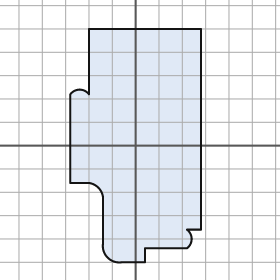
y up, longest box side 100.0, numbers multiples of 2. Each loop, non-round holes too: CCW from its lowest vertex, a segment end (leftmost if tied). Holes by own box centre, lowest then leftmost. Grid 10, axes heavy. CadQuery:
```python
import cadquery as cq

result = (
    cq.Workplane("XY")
    .moveTo(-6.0, -50.0)
    .lineTo(4.0, -50.0)
    .lineTo(4.0, -44.0)
    .lineTo(22.0, -44.0)
    .threePointArc((24.0, -40.0), (22.0, -36.0))
    .lineTo(28.0, -36.0)
    .lineTo(28.0, 50.0)
    .lineTo(-20.0, 50.0)
    .lineTo(-20.0, 22.0)
    .threePointArc((-24.0, 24.0), (-28.0, 22.0))
    .lineTo(-28.0, -16.0)
    .lineTo(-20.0, -16.0)
    .threePointArc((-16.0, -18.0), (-14.0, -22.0))
    .lineTo(-14.0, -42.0)
    .threePointArc((-12.0, -48.0), (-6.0, -50.0))
    .close()
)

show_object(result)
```